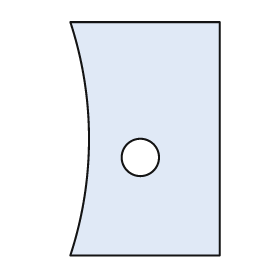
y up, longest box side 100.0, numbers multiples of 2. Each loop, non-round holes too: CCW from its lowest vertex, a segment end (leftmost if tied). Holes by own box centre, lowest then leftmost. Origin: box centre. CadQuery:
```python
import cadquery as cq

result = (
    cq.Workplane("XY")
    .moveTo(-32.0, -50.0)
    .lineTo(32.0, -50.0)
    .lineTo(32.0, 50.0)
    .lineTo(-32.0, 50.0)
    .threePointArc((-24.0, 0.0), (-32.0, -50.0))
    .close()
    .moveTo(-2.0, -8.0)
    .circle(8.0)
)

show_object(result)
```